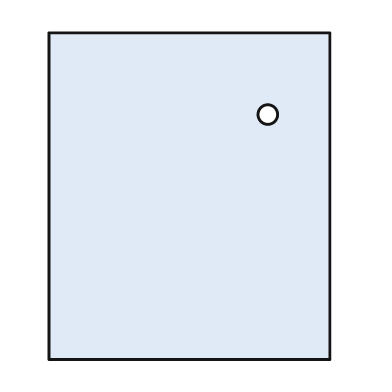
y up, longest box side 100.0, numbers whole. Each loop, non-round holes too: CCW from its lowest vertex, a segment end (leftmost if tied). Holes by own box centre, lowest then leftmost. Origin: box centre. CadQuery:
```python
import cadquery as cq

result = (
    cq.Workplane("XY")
    .moveTo(-43.0, -50.0)
    .lineTo(43.0, -50.0)
    .lineTo(43.0, 50.0)
    .lineTo(-43.0, 50.0)
    .close()
    .moveTo(24.0, 25.0)
    .circle(3.0)
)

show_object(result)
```